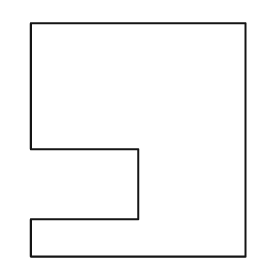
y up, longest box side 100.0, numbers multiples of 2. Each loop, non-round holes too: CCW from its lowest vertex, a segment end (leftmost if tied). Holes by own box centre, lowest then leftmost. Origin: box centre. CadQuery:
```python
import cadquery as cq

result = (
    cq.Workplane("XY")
    .moveTo(-46.0, -50.0)
    .lineTo(46.0, -50.0)
    .lineTo(46.0, 50.0)
    .lineTo(-46.0, 50.0)
    .lineTo(-46.0, -4.0)
    .lineTo(0.0, -4.0)
    .lineTo(0.0, -34.0)
    .lineTo(-46.0, -34.0)
    .close()
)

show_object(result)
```